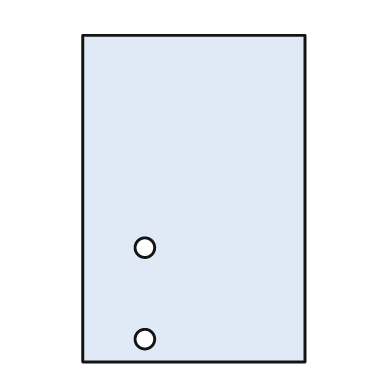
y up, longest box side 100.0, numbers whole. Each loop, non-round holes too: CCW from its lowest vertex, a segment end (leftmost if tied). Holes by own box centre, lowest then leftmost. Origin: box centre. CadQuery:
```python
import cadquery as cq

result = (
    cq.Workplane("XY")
    .moveTo(-34.0, -50.0)
    .lineTo(34.0, -50.0)
    .lineTo(34.0, 50.0)
    .lineTo(-34.0, 50.0)
    .close()
    .moveTo(-15.0, -43.0)
    .circle(3.0)
    .moveTo(-15.0, -15.0)
    .circle(3.0)
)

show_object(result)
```